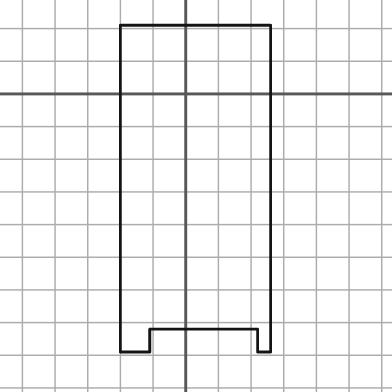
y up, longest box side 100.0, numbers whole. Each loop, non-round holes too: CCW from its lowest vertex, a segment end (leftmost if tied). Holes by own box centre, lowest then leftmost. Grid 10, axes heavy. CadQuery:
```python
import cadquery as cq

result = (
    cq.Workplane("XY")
    .moveTo(-20.0, -79.0)
    .lineTo(-11.0, -79.0)
    .lineTo(-11.0, -72.0)
    .lineTo(22.0, -72.0)
    .lineTo(22.0, -79.0)
    .lineTo(26.0, -79.0)
    .lineTo(26.0, 21.0)
    .lineTo(-20.0, 21.0)
    .close()
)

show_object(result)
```